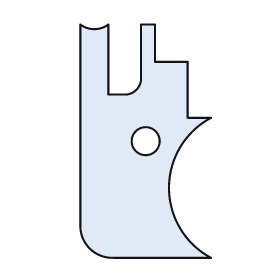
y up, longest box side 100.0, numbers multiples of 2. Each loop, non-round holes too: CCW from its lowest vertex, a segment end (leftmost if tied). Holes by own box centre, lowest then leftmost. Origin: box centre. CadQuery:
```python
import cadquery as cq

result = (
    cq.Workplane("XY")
    .moveTo(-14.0, -50.0)
    .lineTo(28.0, -50.0)
    .threePointArc((10.0, -20.0), (28.0, 10.0))
    .lineTo(18.0, 10.0)
    .lineTo(18.0, 34.0)
    .lineTo(4.0, 34.0)
    .lineTo(4.0, 50.0)
    .lineTo(-2.0, 50.0)
    .lineTo(-2.0, 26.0)
    .threePointArc((-4.0, 22.0), (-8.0, 20.0))
    .lineTo(-16.0, 20.0)
    .lineTo(-16.0, 50.0)
    .threePointArc((-22.0, 48.0), (-28.0, 50.0))
    .lineTo(-28.0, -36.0)
    .threePointArc((-24.0, -46.0), (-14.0, -50.0))
    .close()
    .moveTo(0.0, 0.0)
    .circle(6.0)
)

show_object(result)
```